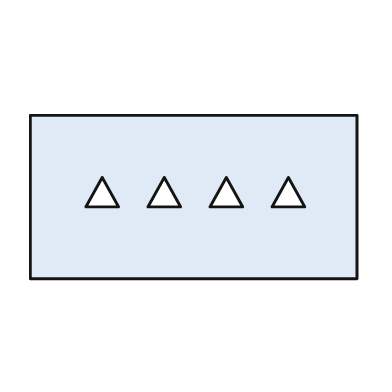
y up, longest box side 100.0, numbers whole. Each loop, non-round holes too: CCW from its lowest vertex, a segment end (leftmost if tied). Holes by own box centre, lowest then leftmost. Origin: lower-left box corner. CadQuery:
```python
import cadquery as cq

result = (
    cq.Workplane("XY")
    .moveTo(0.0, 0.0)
    .lineTo(100.0, 0.0)
    .lineTo(100.0, 50.0)
    .lineTo(0.0, 50.0)
    .close()
    .moveTo(17.0, 22.0)
    .lineTo(27.0, 22.0)
    .lineTo(22.0, 31.0)
    .close()
    .moveTo(36.0, 22.0)
    .lineTo(46.0, 22.0)
    .lineTo(41.0, 31.0)
    .close()
    .moveTo(55.0, 22.0)
    .lineTo(65.0, 22.0)
    .lineTo(60.0, 31.0)
    .close()
    .moveTo(74.0, 22.0)
    .lineTo(84.0, 22.0)
    .lineTo(79.0, 31.0)
    .close()
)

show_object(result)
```